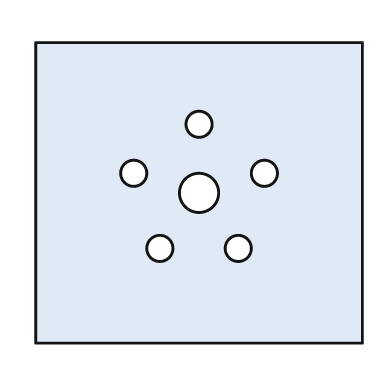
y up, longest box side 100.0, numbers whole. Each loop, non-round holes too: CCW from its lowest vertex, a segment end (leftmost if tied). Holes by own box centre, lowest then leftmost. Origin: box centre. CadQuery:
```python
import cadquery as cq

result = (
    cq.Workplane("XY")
    .moveTo(-50.0, -46.0)
    .lineTo(50.0, -46.0)
    .lineTo(50.0, 46.0)
    .lineTo(-50.0, 46.0)
    .close()
    .moveTo(-12.0, -17.0)
    .circle(4.0)
    .moveTo(12.0, -17.0)
    .circle(4.0)
    .moveTo(0.0, 0.0)
    .circle(6.0)
    .moveTo(-20.0, 6.0)
    .circle(4.0)
    .moveTo(20.0, 6.0)
    .circle(4.0)
    .moveTo(0.0, 21.0)
    .circle(4.0)
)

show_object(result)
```